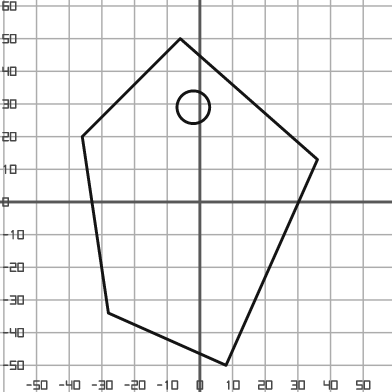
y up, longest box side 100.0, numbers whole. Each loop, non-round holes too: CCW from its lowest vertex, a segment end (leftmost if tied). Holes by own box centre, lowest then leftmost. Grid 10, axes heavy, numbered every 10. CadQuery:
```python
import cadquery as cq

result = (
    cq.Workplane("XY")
    .moveTo(8.0, -50.0)
    .lineTo(36.0, 13.0)
    .lineTo(-6.0, 50.0)
    .lineTo(-36.0, 20.0)
    .lineTo(-28.0, -34.0)
    .close()
    .moveTo(-2.0, 29.0)
    .circle(5.0)
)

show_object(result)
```